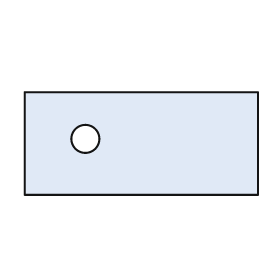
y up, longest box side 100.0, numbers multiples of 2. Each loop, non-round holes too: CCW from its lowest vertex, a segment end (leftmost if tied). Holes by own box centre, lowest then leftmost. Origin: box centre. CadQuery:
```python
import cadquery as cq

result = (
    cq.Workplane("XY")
    .moveTo(-50.0, -22.0)
    .lineTo(50.0, -22.0)
    .lineTo(50.0, 22.0)
    .lineTo(-50.0, 22.0)
    .close()
    .moveTo(-24.0, 2.0)
    .circle(6.0)
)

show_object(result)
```